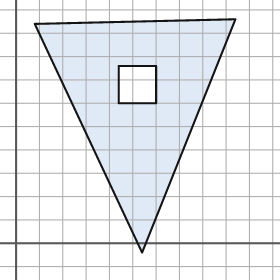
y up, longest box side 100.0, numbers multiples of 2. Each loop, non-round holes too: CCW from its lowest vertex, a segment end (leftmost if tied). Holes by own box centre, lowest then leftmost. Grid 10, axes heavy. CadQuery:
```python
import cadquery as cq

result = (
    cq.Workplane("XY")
    .moveTo(54.0, -4.0)
    .lineTo(94.0, 96.0)
    .lineTo(8.0, 94.0)
    .close()
    .moveTo(44.0, 60.0)
    .lineTo(60.0, 60.0)
    .lineTo(60.0, 76.0)
    .lineTo(44.0, 76.0)
    .close()
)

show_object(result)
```